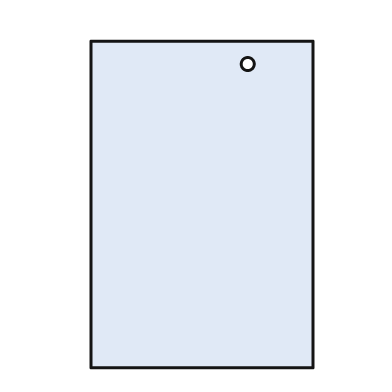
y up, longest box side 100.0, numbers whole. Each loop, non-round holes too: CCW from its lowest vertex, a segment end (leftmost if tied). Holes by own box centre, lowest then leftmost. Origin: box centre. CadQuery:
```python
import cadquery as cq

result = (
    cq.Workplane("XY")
    .moveTo(-34.0, -50.0)
    .lineTo(34.0, -50.0)
    .lineTo(34.0, 50.0)
    .lineTo(-34.0, 50.0)
    .close()
    .moveTo(14.0, 43.0)
    .circle(2.0)
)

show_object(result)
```